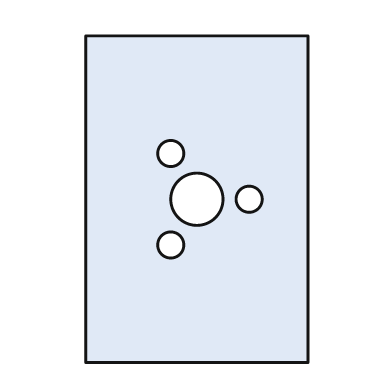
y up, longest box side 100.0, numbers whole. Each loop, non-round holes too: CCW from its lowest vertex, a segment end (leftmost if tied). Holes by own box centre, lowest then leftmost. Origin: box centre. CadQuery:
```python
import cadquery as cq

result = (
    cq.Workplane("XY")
    .moveTo(-34.0, -50.0)
    .lineTo(34.0, -50.0)
    .lineTo(34.0, 50.0)
    .lineTo(-34.0, 50.0)
    .close()
    .moveTo(-8.0, -14.0)
    .circle(4.0)
    .moveTo(0.0, 0.0)
    .circle(8.0)
    .moveTo(16.0, 0.0)
    .circle(4.0)
    .moveTo(-8.0, 14.0)
    .circle(4.0)
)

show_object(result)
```